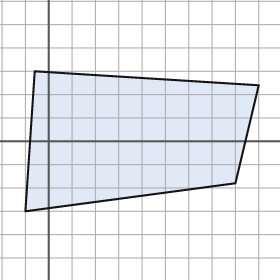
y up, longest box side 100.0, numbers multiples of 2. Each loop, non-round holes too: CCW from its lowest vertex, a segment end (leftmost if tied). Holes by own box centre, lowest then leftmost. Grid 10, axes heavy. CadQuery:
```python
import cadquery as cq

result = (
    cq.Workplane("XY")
    .moveTo(-10.0, -30.0)
    .lineTo(80.0, -18.0)
    .lineTo(90.0, 24.0)
    .lineTo(-6.0, 30.0)
    .close()
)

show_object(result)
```